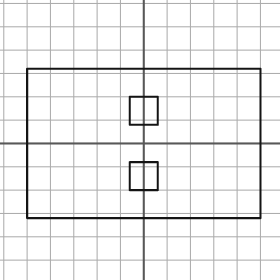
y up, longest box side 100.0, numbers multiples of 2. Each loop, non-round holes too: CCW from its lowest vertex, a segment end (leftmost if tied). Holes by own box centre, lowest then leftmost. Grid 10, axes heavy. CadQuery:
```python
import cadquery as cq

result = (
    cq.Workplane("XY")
    .moveTo(-50.0, -32.0)
    .lineTo(50.0, -32.0)
    .lineTo(50.0, 32.0)
    .lineTo(-50.0, 32.0)
    .close()
    .moveTo(-6.0, -20.0)
    .lineTo(6.0, -20.0)
    .lineTo(6.0, -8.0)
    .lineTo(-6.0, -8.0)
    .close()
    .moveTo(-6.0, 8.0)
    .lineTo(6.0, 8.0)
    .lineTo(6.0, 20.0)
    .lineTo(-6.0, 20.0)
    .close()
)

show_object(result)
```